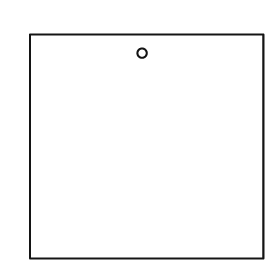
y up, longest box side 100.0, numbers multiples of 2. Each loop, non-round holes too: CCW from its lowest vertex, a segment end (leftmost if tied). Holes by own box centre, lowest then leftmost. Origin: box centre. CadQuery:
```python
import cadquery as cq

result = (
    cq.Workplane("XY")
    .moveTo(-50.0, -48.0)
    .lineTo(50.0, -48.0)
    .lineTo(50.0, 48.0)
    .lineTo(-50.0, 48.0)
    .close()
    .moveTo(-2.0, 40.0)
    .circle(2.0)
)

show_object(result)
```